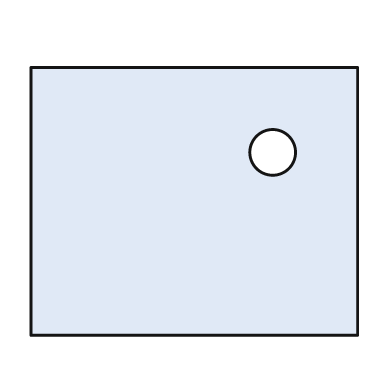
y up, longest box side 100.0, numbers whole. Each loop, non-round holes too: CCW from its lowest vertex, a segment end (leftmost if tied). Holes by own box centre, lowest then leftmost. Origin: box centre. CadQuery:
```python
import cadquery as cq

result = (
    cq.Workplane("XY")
    .moveTo(-50.0, -41.0)
    .lineTo(50.0, -41.0)
    .lineTo(50.0, 41.0)
    .lineTo(-50.0, 41.0)
    .close()
    .moveTo(24.0, 15.0)
    .circle(7.0)
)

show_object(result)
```